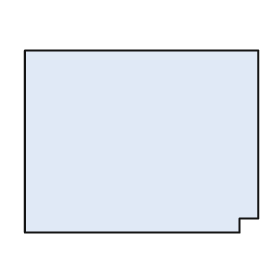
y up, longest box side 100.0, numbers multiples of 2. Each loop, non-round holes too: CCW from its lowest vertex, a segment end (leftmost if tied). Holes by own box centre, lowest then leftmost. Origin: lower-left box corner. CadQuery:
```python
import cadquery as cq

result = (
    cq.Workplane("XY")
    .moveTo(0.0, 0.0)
    .lineTo(92.0, 0.0)
    .lineTo(92.0, 6.0)
    .lineTo(100.0, 6.0)
    .lineTo(100.0, 78.0)
    .lineTo(0.0, 78.0)
    .close()
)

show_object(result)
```